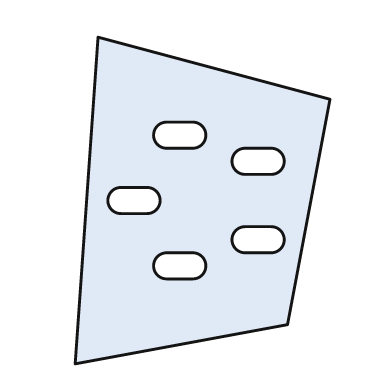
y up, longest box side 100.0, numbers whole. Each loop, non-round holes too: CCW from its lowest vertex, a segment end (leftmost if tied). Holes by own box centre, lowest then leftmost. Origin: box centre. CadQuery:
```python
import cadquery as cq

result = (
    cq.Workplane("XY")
    .moveTo(-39.0, -50.0)
    .lineTo(26.0, -38.0)
    .lineTo(39.0, 31.0)
    .lineTo(-32.0, 50.0)
    .close()
    .moveTo(-11.0, -24.0)
    .lineTo(-3.0, -24.0)
    .threePointArc((1.0, -20.0), (-3.0, -16.0))
    .lineTo(-11.0, -16.0)
    .threePointArc((-15.0, -20.0), (-11.0, -24.0))
    .close()
    .moveTo(13.0, -16.0)
    .lineTo(21.0, -16.0)
    .threePointArc((25.0, -12.0), (21.0, -8.0))
    .lineTo(13.0, -8.0)
    .threePointArc((9.0, -12.0), (13.0, -16.0))
    .close()
    .moveTo(-25.0, -4.0)
    .lineTo(-17.0, -4.0)
    .threePointArc((-13.0, 0.0), (-17.0, 4.0))
    .lineTo(-25.0, 4.0)
    .threePointArc((-29.0, 0.0), (-25.0, -4.0))
    .close()
    .moveTo(13.0, 8.0)
    .lineTo(21.0, 8.0)
    .threePointArc((25.0, 12.0), (21.0, 16.0))
    .lineTo(13.0, 16.0)
    .threePointArc((9.0, 12.0), (13.0, 8.0))
    .close()
    .moveTo(-11.0, 16.0)
    .lineTo(-3.0, 16.0)
    .threePointArc((1.0, 20.0), (-3.0, 24.0))
    .lineTo(-11.0, 24.0)
    .threePointArc((-15.0, 20.0), (-11.0, 16.0))
    .close()
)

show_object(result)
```